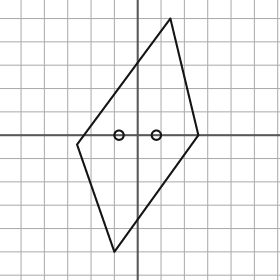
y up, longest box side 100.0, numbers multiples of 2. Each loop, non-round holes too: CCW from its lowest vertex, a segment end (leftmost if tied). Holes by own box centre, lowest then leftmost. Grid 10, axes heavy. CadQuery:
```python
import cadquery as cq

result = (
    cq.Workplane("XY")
    .moveTo(-10.0, -50.0)
    .lineTo(26.0, 0.0)
    .lineTo(14.0, 50.0)
    .lineTo(-26.0, -4.0)
    .close()
    .moveTo(-8.0, 0.0)
    .circle(2.0)
    .moveTo(8.0, 0.0)
    .circle(2.0)
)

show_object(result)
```